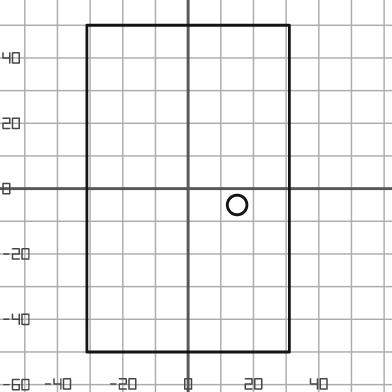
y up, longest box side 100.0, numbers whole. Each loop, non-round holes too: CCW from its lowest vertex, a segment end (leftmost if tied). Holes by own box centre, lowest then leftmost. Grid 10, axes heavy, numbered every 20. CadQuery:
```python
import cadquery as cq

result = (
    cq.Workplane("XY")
    .moveTo(-31.0, -50.0)
    .lineTo(31.0, -50.0)
    .lineTo(31.0, 50.0)
    .lineTo(-31.0, 50.0)
    .close()
    .moveTo(15.0, -5.0)
    .circle(3.0)
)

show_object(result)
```